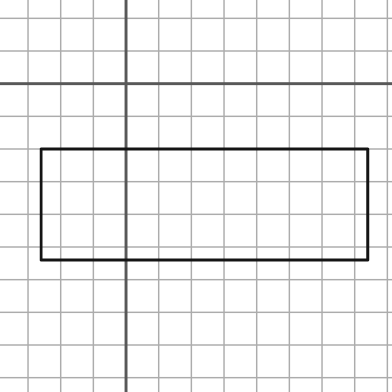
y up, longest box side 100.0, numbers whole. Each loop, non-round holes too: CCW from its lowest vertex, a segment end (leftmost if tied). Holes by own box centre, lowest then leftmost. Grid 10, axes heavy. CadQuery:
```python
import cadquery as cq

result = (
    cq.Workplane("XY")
    .moveTo(-26.0, -54.0)
    .lineTo(74.0, -54.0)
    .lineTo(74.0, -20.0)
    .lineTo(-26.0, -20.0)
    .close()
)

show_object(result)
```